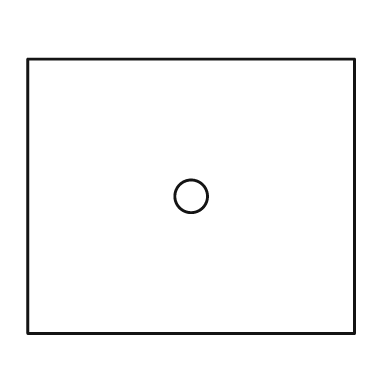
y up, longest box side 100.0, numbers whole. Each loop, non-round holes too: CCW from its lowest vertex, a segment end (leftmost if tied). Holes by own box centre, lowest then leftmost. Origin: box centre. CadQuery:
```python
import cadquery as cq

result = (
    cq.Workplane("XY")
    .moveTo(-50.0, -42.0)
    .lineTo(50.0, -42.0)
    .lineTo(50.0, 42.0)
    .lineTo(-50.0, 42.0)
    .close()
    .moveTo(0.0, 0.0)
    .circle(5.0)
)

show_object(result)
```